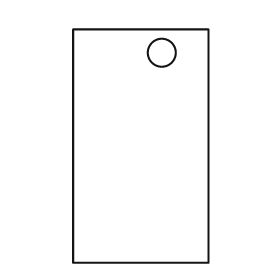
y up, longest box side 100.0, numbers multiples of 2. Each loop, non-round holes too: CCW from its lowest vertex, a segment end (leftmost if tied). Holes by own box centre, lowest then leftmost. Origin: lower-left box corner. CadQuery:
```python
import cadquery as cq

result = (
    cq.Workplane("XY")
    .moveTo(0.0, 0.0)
    .lineTo(58.0, 0.0)
    .lineTo(58.0, 100.0)
    .lineTo(0.0, 100.0)
    .close()
    .moveTo(38.0, 90.0)
    .circle(6.0)
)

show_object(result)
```